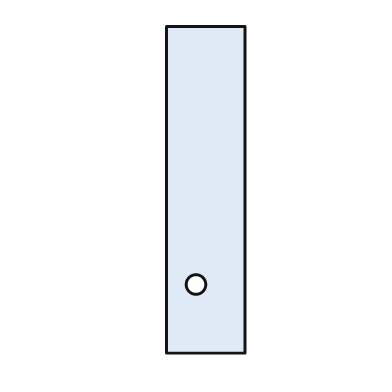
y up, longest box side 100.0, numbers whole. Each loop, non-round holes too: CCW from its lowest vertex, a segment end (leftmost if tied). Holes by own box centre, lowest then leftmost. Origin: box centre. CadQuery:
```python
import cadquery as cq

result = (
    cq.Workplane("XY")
    .moveTo(-12.0, -50.0)
    .lineTo(12.0, -50.0)
    .lineTo(12.0, 50.0)
    .lineTo(-12.0, 50.0)
    .close()
    .moveTo(-3.0, -29.0)
    .circle(3.0)
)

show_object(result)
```